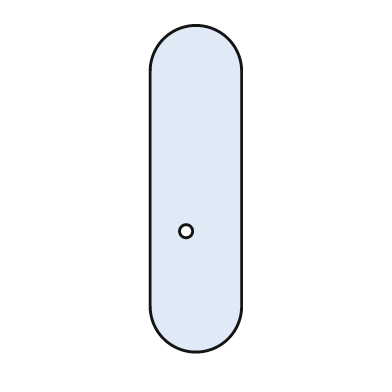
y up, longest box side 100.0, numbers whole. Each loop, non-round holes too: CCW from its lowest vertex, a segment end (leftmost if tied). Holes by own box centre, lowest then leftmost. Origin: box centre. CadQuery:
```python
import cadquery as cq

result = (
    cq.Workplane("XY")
    .moveTo(-14.0, -36.0)
    .threePointArc((0.0, -50.0), (14.0, -36.0))
    .lineTo(14.0, 36.0)
    .threePointArc((0.0, 50.0), (-14.0, 36.0))
    .close()
    .moveTo(-3.0, -13.0)
    .circle(2.0)
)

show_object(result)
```